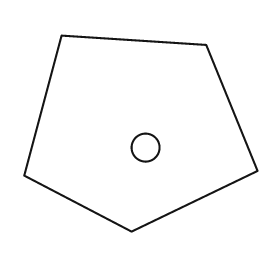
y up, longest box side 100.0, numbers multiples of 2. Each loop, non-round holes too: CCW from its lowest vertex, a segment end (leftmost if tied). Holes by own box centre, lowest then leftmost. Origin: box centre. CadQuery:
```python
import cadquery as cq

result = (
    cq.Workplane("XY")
    .moveTo(-4.0, -42.0)
    .lineTo(50.0, -16.0)
    .lineTo(28.0, 38.0)
    .lineTo(-34.0, 42.0)
    .lineTo(-50.0, -18.0)
    .close()
    .moveTo(2.0, -6.0)
    .circle(6.0)
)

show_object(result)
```